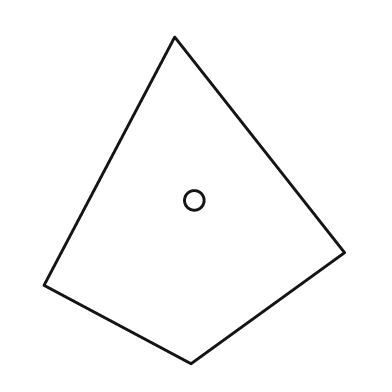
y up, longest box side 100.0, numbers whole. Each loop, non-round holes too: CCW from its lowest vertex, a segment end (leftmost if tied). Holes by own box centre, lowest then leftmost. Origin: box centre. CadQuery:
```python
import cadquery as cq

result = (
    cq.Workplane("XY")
    .moveTo(-1.0, -50.0)
    .lineTo(46.0, -16.0)
    .lineTo(-6.0, 50.0)
    .lineTo(-46.0, -26.0)
    .close()
    .moveTo(0.0, 0.0)
    .circle(3.0)
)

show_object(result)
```